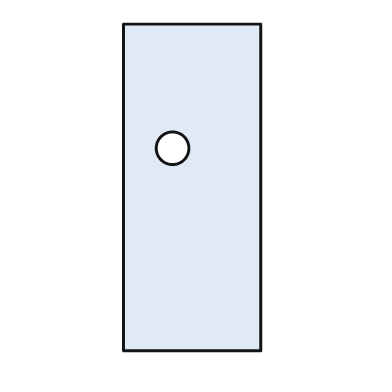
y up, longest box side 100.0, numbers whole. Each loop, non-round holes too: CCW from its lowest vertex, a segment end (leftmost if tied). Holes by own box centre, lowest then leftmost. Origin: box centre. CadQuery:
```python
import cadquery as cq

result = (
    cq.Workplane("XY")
    .moveTo(-21.0, -50.0)
    .lineTo(21.0, -50.0)
    .lineTo(21.0, 50.0)
    .lineTo(-21.0, 50.0)
    .close()
    .moveTo(-6.0, 12.0)
    .circle(5.0)
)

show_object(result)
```